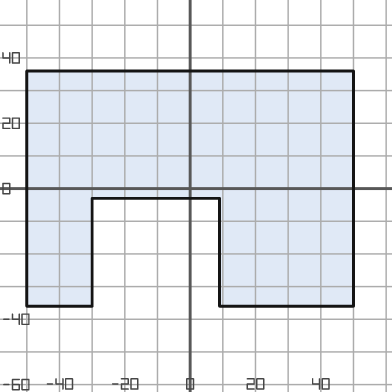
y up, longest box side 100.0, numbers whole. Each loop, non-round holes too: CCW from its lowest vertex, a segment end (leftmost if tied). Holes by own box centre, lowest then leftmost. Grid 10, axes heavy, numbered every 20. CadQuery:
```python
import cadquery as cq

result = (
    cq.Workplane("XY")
    .moveTo(-50.0, -36.0)
    .lineTo(-30.0, -36.0)
    .lineTo(-30.0, -3.0)
    .lineTo(9.0, -3.0)
    .lineTo(9.0, -36.0)
    .lineTo(50.0, -36.0)
    .lineTo(50.0, 36.0)
    .lineTo(-50.0, 36.0)
    .close()
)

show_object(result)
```